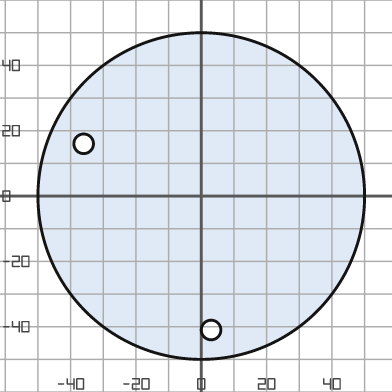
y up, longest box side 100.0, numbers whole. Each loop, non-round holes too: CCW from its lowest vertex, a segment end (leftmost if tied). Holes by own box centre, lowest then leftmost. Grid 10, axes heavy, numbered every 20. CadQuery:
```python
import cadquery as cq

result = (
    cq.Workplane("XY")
    .moveTo(0.0, 0.0)
    .circle(50.0)
    .moveTo(3.0, -41.0)
    .circle(3.0)
    .moveTo(-36.0, 16.0)
    .circle(3.0)
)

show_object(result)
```